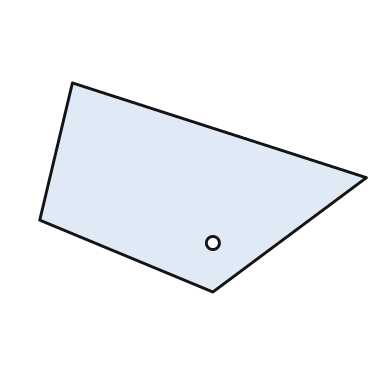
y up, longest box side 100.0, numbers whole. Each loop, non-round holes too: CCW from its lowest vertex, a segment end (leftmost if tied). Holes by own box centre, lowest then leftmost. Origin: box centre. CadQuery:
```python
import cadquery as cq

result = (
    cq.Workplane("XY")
    .moveTo(3.0, -32.0)
    .lineTo(50.0, 3.0)
    .lineTo(-40.0, 32.0)
    .lineTo(-50.0, -10.0)
    .close()
    .moveTo(3.0, -17.0)
    .circle(2.0)
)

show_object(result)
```